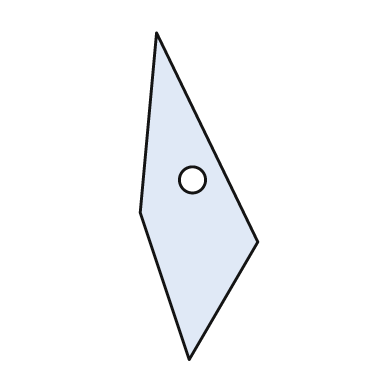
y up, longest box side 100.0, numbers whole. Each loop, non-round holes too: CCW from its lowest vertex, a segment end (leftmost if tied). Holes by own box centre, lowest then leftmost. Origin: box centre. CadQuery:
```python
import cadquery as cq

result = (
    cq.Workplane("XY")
    .moveTo(-3.0, -50.0)
    .lineTo(18.0, -14.0)
    .lineTo(-13.0, 50.0)
    .lineTo(-18.0, -5.0)
    .close()
    .moveTo(-2.0, 5.0)
    .circle(4.0)
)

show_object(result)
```